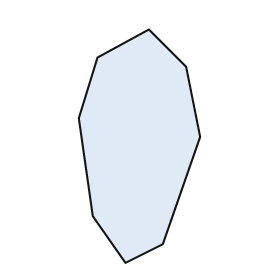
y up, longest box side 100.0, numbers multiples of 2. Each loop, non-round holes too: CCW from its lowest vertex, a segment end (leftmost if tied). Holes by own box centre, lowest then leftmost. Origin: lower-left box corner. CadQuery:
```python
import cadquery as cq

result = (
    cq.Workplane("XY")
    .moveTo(20.0, 0.0)
    .lineTo(36.0, 8.0)
    .lineTo(52.0, 54.0)
    .lineTo(46.0, 84.0)
    .lineTo(30.0, 100.0)
    .lineTo(8.0, 88.0)
    .lineTo(0.0, 62.0)
    .lineTo(6.0, 20.0)
    .close()
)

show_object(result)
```